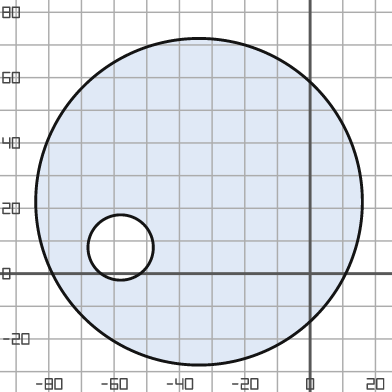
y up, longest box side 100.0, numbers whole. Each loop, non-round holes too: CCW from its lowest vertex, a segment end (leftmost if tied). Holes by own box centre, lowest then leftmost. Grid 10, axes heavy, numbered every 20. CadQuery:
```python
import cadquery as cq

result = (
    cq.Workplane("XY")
    .moveTo(-34.0, 22.0)
    .circle(50.0)
    .moveTo(-58.0, 8.0)
    .circle(10.0)
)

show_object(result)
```